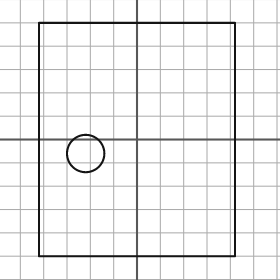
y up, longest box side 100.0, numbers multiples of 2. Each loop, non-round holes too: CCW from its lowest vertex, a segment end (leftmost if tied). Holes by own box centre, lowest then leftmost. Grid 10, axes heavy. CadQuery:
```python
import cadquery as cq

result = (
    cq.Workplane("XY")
    .moveTo(-42.0, -50.0)
    .lineTo(42.0, -50.0)
    .lineTo(42.0, 50.0)
    .lineTo(-42.0, 50.0)
    .close()
    .moveTo(-22.0, -6.0)
    .circle(8.0)
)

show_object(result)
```